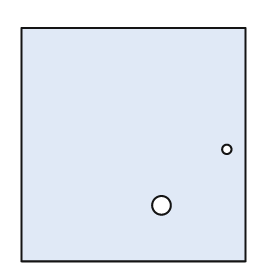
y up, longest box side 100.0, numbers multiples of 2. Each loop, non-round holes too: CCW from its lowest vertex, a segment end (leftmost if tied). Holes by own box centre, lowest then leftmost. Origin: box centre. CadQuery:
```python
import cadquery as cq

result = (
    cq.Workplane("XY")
    .moveTo(-48.0, -50.0)
    .lineTo(48.0, -50.0)
    .lineTo(48.0, 50.0)
    .lineTo(-48.0, 50.0)
    .close()
    .moveTo(12.0, -26.0)
    .circle(4.0)
    .moveTo(40.0, -2.0)
    .circle(2.0)
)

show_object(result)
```